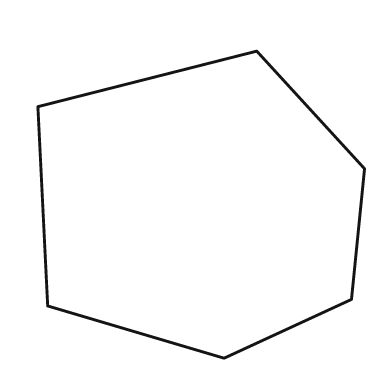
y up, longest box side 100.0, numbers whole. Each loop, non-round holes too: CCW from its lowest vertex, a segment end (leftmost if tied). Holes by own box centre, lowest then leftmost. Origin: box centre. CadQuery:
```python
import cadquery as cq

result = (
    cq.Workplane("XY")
    .moveTo(7.0, -47.0)
    .lineTo(46.0, -29.0)
    .lineTo(50.0, 11.0)
    .lineTo(17.0, 47.0)
    .lineTo(-50.0, 30.0)
    .lineTo(-47.0, -31.0)
    .close()
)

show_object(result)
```